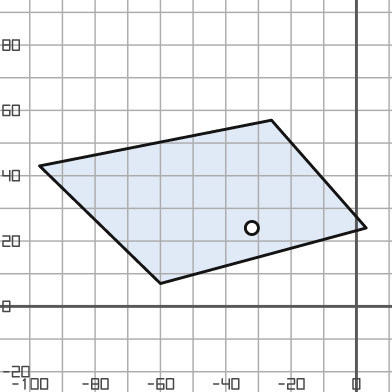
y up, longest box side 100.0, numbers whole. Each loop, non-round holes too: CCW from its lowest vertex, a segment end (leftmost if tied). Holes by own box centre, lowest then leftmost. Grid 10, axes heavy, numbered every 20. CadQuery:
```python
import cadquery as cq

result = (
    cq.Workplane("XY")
    .moveTo(-60.0, 7.0)
    .lineTo(3.0, 24.0)
    .lineTo(-26.0, 57.0)
    .lineTo(-97.0, 43.0)
    .close()
    .moveTo(-32.0, 24.0)
    .circle(2.0)
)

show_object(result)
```